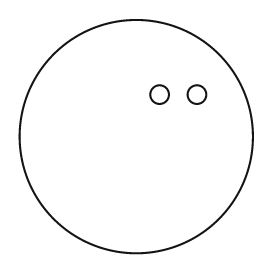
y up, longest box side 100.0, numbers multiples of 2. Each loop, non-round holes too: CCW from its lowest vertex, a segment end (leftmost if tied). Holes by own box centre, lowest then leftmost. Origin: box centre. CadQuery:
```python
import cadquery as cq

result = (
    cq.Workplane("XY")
    .moveTo(0.0, 0.0)
    .circle(50.0)
    .moveTo(10.0, 18.0)
    .circle(4.0)
    .moveTo(26.0, 18.0)
    .circle(4.0)
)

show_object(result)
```